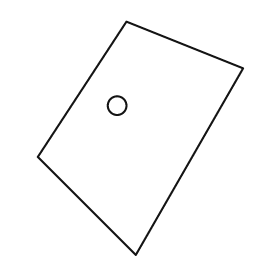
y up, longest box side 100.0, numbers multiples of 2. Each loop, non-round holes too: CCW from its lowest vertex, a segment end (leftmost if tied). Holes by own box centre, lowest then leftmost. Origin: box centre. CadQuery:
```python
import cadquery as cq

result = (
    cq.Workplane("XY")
    .moveTo(-2.0, -50.0)
    .lineTo(44.0, 30.0)
    .lineTo(-6.0, 50.0)
    .lineTo(-44.0, -8.0)
    .close()
    .moveTo(-10.0, 14.0)
    .circle(4.0)
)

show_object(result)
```